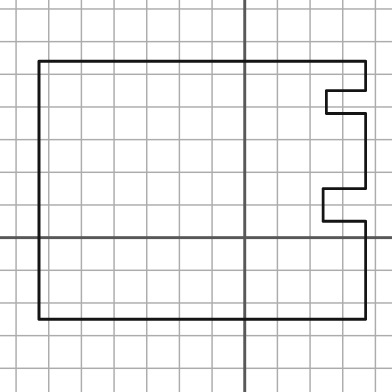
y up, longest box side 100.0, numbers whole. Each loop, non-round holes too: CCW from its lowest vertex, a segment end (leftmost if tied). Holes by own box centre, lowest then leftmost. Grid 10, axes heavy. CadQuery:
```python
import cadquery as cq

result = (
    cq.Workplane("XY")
    .moveTo(-63.0, -25.0)
    .lineTo(37.0, -25.0)
    .lineTo(37.0, 5.0)
    .lineTo(24.0, 5.0)
    .lineTo(24.0, 15.0)
    .lineTo(37.0, 15.0)
    .lineTo(37.0, 38.0)
    .lineTo(25.0, 38.0)
    .lineTo(25.0, 45.0)
    .lineTo(37.0, 45.0)
    .lineTo(37.0, 54.0)
    .lineTo(-63.0, 54.0)
    .close()
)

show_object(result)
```